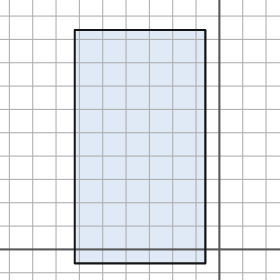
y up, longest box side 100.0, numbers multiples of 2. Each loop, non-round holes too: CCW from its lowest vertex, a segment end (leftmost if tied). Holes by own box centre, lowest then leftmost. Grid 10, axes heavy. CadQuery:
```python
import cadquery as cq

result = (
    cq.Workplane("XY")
    .moveTo(-62.0, -6.0)
    .lineTo(-6.0, -6.0)
    .lineTo(-6.0, 94.0)
    .lineTo(-62.0, 94.0)
    .close()
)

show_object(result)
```